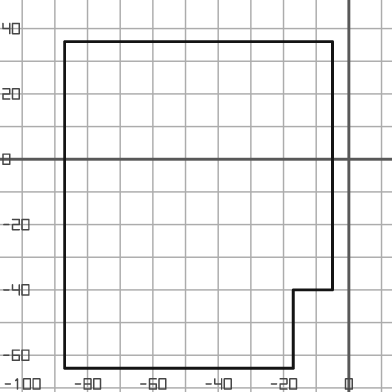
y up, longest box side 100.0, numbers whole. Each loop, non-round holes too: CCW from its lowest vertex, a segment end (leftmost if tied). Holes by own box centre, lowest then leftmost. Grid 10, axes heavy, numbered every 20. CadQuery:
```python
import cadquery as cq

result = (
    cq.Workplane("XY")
    .moveTo(-87.0, -64.0)
    .lineTo(-17.0, -64.0)
    .lineTo(-17.0, -40.0)
    .lineTo(-5.0, -40.0)
    .lineTo(-5.0, 36.0)
    .lineTo(-87.0, 36.0)
    .close()
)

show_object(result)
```